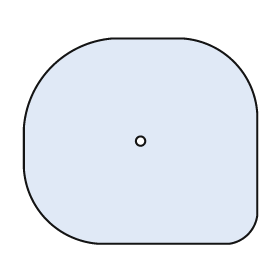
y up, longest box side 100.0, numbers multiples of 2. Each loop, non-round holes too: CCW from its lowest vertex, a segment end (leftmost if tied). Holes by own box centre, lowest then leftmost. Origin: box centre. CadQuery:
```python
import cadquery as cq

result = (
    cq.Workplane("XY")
    .moveTo(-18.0, -44.0)
    .lineTo(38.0, -44.0)
    .threePointArc((46.0, -40.0), (50.0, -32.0))
    .lineTo(50.0, 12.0)
    .threePointArc((40.0, 34.0), (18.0, 44.0))
    .lineTo(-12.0, 44.0)
    .threePointArc((-38.0, 32.0), (-50.0, 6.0))
    .lineTo(-50.0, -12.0)
    .threePointArc((-40.0, -34.0), (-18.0, -44.0))
    .close()
    .moveTo(0.0, 0.0)
    .circle(2.0)
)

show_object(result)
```